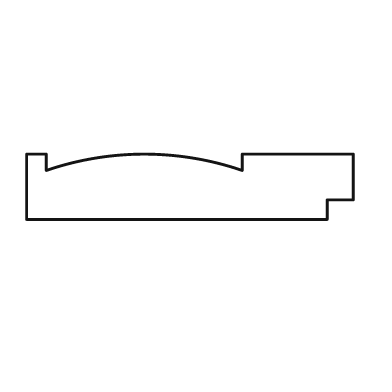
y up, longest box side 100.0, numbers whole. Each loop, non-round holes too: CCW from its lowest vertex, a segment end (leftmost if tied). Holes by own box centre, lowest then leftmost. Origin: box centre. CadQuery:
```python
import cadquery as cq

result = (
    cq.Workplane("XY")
    .moveTo(-50.0, -10.0)
    .lineTo(42.0, -10.0)
    .lineTo(42.0, -4.0)
    .lineTo(50.0, -4.0)
    .lineTo(50.0, 10.0)
    .lineTo(16.0, 10.0)
    .lineTo(16.0, 5.0)
    .threePointArc((-14.0, 10.0), (-44.0, 5.0))
    .lineTo(-44.0, 10.0)
    .lineTo(-50.0, 10.0)
    .close()
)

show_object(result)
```